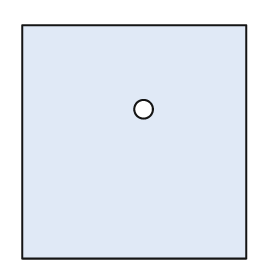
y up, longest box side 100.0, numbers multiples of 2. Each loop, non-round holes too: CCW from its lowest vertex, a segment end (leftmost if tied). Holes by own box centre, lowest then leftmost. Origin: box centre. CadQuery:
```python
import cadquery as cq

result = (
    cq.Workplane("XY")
    .moveTo(-48.0, -50.0)
    .lineTo(48.0, -50.0)
    .lineTo(48.0, 50.0)
    .lineTo(-48.0, 50.0)
    .close()
    .moveTo(4.0, 14.0)
    .circle(4.0)
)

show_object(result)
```